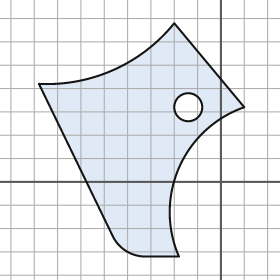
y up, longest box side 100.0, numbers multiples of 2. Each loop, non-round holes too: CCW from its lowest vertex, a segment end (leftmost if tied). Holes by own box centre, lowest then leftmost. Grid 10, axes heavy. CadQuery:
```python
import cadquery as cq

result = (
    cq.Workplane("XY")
    .moveTo(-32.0, -32.0)
    .lineTo(-18.0, -32.0)
    .threePointArc((-18.0, 6.0), (10.0, 32.0))
    .lineTo(-20.0, 68.0)
    .threePointArc((-46.0, 48.0), (-78.0, 42.0))
    .lineTo(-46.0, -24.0)
    .threePointArc((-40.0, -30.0), (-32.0, -32.0))
    .close()
    .moveTo(-14.0, 32.0)
    .circle(6.0)
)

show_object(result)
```